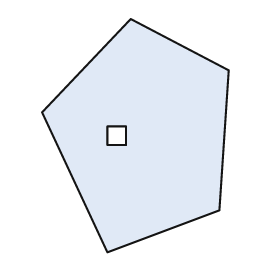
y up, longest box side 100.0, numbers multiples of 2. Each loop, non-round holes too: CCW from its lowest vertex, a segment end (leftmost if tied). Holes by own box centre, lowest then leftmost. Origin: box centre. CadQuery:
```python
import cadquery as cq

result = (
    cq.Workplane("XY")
    .moveTo(-12.0, -50.0)
    .lineTo(36.0, -32.0)
    .lineTo(40.0, 28.0)
    .lineTo(-2.0, 50.0)
    .lineTo(-40.0, 10.0)
    .close()
    .moveTo(-12.0, -4.0)
    .lineTo(-4.0, -4.0)
    .lineTo(-4.0, 4.0)
    .lineTo(-12.0, 4.0)
    .close()
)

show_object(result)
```